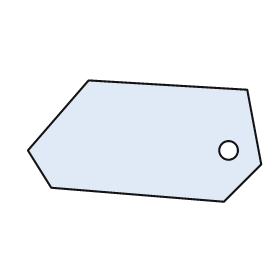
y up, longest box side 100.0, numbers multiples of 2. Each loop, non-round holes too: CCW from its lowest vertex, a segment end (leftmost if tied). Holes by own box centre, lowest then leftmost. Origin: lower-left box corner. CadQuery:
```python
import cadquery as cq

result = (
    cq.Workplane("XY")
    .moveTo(84.0, 0.0)
    .lineTo(100.0, 16.0)
    .lineTo(94.0, 48.0)
    .lineTo(26.0, 52.0)
    .lineTo(0.0, 22.0)
    .lineTo(10.0, 6.0)
    .close()
    .moveTo(86.0, 22.0)
    .circle(4.0)
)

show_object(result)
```